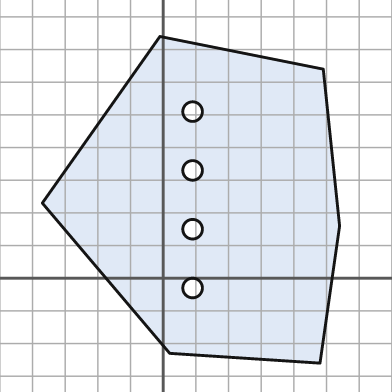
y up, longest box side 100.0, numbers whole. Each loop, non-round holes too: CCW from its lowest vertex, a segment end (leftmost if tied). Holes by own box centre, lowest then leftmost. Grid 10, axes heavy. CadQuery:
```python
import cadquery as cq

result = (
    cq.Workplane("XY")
    .moveTo(48.0, -26.0)
    .lineTo(54.0, 16.0)
    .lineTo(49.0, 64.0)
    .lineTo(-1.0, 74.0)
    .lineTo(-37.0, 23.0)
    .lineTo(2.0, -23.0)
    .close()
    .moveTo(9.0, -3.0)
    .circle(3.0)
    .moveTo(9.0, 15.0)
    .circle(3.0)
    .moveTo(9.0, 33.0)
    .circle(3.0)
    .moveTo(9.0, 51.0)
    .circle(3.0)
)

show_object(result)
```